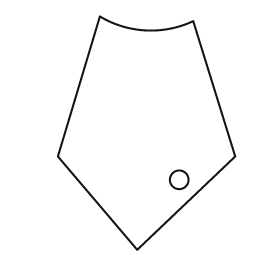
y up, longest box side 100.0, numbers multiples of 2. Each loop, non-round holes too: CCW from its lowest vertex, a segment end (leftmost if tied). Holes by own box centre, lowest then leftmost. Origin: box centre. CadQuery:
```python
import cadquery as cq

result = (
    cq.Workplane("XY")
    .moveTo(-4.0, -50.0)
    .lineTo(38.0, -10.0)
    .lineTo(20.0, 48.0)
    .threePointArc((0.0, 44.0), (-20.0, 50.0))
    .lineTo(-38.0, -10.0)
    .close()
    .moveTo(14.0, -20.0)
    .circle(4.0)
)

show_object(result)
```